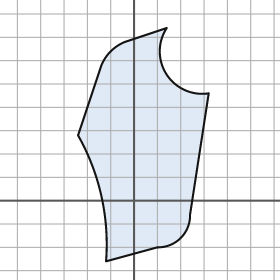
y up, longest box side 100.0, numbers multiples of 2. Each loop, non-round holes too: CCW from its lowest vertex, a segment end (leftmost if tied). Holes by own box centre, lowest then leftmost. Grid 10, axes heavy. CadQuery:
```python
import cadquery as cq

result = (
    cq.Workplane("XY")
    .moveTo(-12.0, -26.0)
    .lineTo(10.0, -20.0)
    .threePointArc((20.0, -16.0), (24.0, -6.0))
    .lineTo(32.0, 46.0)
    .threePointArc((14.0, 54.0), (14.0, 74.0))
    .lineTo(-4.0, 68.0)
    .threePointArc((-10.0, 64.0), (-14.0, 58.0))
    .lineTo(-24.0, 28.0)
    .threePointArc((-14.0, 2.0), (-12.0, -26.0))
    .close()
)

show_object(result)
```